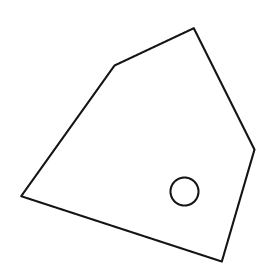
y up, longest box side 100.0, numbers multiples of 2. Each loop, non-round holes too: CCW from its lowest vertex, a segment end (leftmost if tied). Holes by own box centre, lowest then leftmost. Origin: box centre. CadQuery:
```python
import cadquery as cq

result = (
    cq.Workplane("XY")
    .moveTo(36.0, -50.0)
    .lineTo(50.0, -2.0)
    .lineTo(24.0, 50.0)
    .lineTo(-10.0, 34.0)
    .lineTo(-50.0, -22.0)
    .close()
    .moveTo(20.0, -20.0)
    .circle(6.0)
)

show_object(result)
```